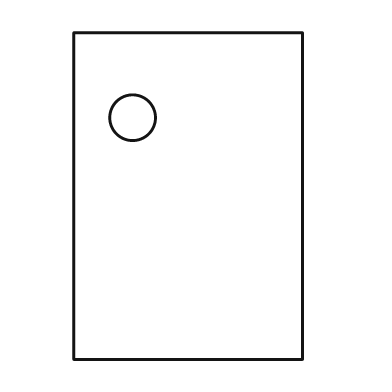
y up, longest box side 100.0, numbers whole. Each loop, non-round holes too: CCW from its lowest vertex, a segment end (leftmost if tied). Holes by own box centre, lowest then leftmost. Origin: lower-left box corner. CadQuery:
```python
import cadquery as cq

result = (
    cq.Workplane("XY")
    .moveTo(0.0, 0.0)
    .lineTo(70.0, 0.0)
    .lineTo(70.0, 100.0)
    .lineTo(0.0, 100.0)
    .close()
    .moveTo(18.0, 74.0)
    .circle(7.0)
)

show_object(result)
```